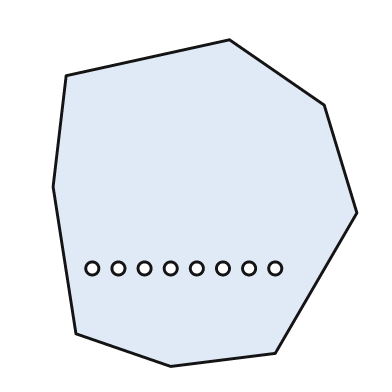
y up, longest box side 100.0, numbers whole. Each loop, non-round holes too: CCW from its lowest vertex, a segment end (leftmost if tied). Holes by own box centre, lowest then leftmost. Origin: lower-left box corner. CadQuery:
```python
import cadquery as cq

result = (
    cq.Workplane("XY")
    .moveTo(36.0, 0.0)
    .lineTo(68.0, 4.0)
    .lineTo(93.0, 47.0)
    .lineTo(83.0, 80.0)
    .lineTo(54.0, 100.0)
    .lineTo(4.0, 89.0)
    .lineTo(0.0, 55.0)
    .lineTo(7.0, 10.0)
    .close()
    .moveTo(12.0, 30.0)
    .circle(2.0)
    .moveTo(20.0, 30.0)
    .circle(2.0)
    .moveTo(28.0, 30.0)
    .circle(2.0)
    .moveTo(36.0, 30.0)
    .circle(2.0)
    .moveTo(44.0, 30.0)
    .circle(2.0)
    .moveTo(52.0, 30.0)
    .circle(2.0)
    .moveTo(60.0, 30.0)
    .circle(2.0)
    .moveTo(68.0, 30.0)
    .circle(2.0)
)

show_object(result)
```